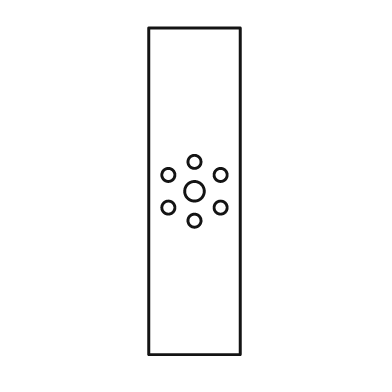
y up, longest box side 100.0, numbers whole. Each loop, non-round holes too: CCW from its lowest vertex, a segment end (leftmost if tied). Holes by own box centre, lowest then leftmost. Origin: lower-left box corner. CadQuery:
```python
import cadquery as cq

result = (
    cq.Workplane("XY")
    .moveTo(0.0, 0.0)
    .lineTo(28.0, 0.0)
    .lineTo(28.0, 100.0)
    .lineTo(0.0, 100.0)
    .close()
    .moveTo(14.0, 41.0)
    .circle(2.0)
    .moveTo(6.0, 45.0)
    .circle(2.0)
    .moveTo(22.0, 45.0)
    .circle(2.0)
    .moveTo(14.0, 50.0)
    .circle(3.0)
    .moveTo(6.0, 55.0)
    .circle(2.0)
    .moveTo(22.0, 55.0)
    .circle(2.0)
    .moveTo(14.0, 59.0)
    .circle(2.0)
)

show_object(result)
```